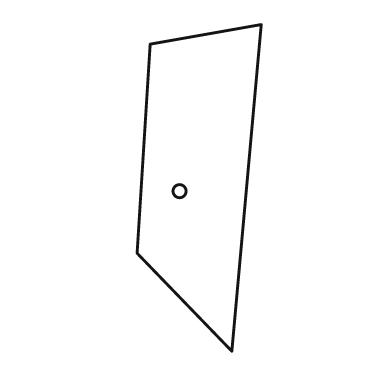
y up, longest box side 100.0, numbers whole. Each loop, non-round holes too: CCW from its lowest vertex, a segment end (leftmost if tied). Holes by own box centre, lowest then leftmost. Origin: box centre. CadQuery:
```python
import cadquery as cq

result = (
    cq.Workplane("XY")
    .moveTo(10.0, -50.0)
    .lineTo(19.0, 50.0)
    .lineTo(-15.0, 44.0)
    .lineTo(-19.0, -20.0)
    .close()
    .moveTo(-6.0, -1.0)
    .circle(2.0)
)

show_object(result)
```